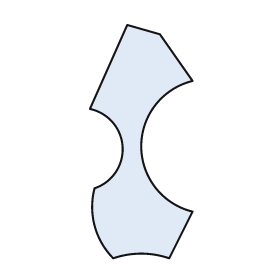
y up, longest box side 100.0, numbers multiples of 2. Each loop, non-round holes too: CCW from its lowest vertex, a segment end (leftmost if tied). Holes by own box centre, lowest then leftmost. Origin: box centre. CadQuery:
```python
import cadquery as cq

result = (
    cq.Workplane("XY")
    .moveTo(-12.0, -50.0)
    .threePointArc((0.0, -48.0), (12.0, -50.0))
    .lineTo(22.0, -30.0)
    .threePointArc((0.0, -2.0), (22.0, 26.0))
    .lineTo(8.0, 46.0)
    .lineTo(-6.0, 50.0)
    .lineTo(-22.0, 14.0)
    .threePointArc((-8.0, -2.0), (-20.0, -20.0))
    .threePointArc((-20.0, -36.0), (-12.0, -50.0))
    .close()
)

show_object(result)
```